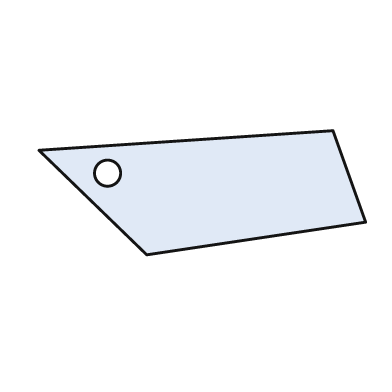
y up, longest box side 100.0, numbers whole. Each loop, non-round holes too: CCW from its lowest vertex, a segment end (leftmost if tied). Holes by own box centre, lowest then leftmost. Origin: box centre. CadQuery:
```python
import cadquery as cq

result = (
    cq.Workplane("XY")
    .moveTo(-17.0, -19.0)
    .lineTo(50.0, -9.0)
    .lineTo(40.0, 19.0)
    .lineTo(-50.0, 13.0)
    .close()
    .moveTo(-29.0, 6.0)
    .circle(4.0)
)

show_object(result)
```